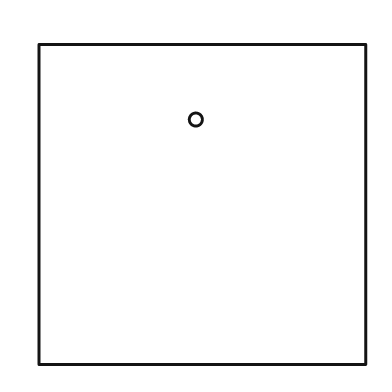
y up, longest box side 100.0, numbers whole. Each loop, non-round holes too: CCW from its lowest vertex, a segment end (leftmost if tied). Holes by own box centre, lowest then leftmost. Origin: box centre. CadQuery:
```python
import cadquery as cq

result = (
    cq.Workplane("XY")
    .moveTo(-50.0, -49.0)
    .lineTo(50.0, -49.0)
    .lineTo(50.0, 49.0)
    .lineTo(-50.0, 49.0)
    .close()
    .moveTo(-2.0, 26.0)
    .circle(2.0)
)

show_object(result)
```